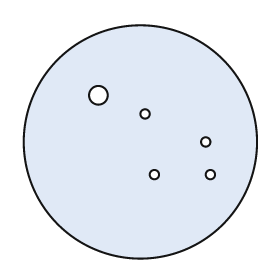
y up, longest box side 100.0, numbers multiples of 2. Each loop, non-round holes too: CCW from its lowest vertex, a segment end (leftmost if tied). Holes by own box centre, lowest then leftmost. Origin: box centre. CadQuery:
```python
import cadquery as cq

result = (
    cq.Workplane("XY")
    .moveTo(0.0, 0.0)
    .circle(50.0)
    .moveTo(6.0, -14.0)
    .circle(2.0)
    .moveTo(30.0, -14.0)
    .circle(2.0)
    .moveTo(28.0, 0.0)
    .circle(2.0)
    .moveTo(2.0, 12.0)
    .circle(2.0)
    .moveTo(-18.0, 20.0)
    .circle(4.0)
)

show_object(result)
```